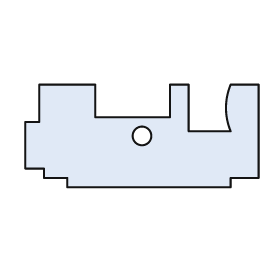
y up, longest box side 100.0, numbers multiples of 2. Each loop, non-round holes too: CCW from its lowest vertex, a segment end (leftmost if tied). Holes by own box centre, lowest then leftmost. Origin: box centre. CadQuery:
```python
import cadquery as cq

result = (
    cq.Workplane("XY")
    .moveTo(-32.0, -22.0)
    .lineTo(38.0, -22.0)
    .lineTo(38.0, -18.0)
    .lineTo(50.0, -18.0)
    .lineTo(50.0, 22.0)
    .lineTo(38.0, 22.0)
    .threePointArc((36.0, 12.0), (38.0, 2.0))
    .lineTo(20.0, 2.0)
    .lineTo(20.0, 22.0)
    .lineTo(12.0, 22.0)
    .lineTo(12.0, 8.0)
    .lineTo(-20.0, 8.0)
    .lineTo(-20.0, 22.0)
    .lineTo(-44.0, 22.0)
    .lineTo(-44.0, 6.0)
    .lineTo(-50.0, 6.0)
    .lineTo(-50.0, -14.0)
    .lineTo(-42.0, -14.0)
    .lineTo(-42.0, -18.0)
    .lineTo(-32.0, -18.0)
    .close()
    .moveTo(0.0, 0.0)
    .circle(4.0)
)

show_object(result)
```